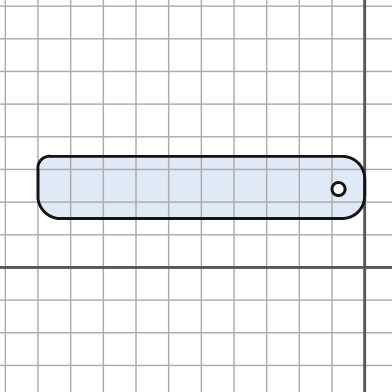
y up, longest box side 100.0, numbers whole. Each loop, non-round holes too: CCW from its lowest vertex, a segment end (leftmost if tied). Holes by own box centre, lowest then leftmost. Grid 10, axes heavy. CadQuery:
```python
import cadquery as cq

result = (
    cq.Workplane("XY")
    .moveTo(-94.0, 15.0)
    .lineTo(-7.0, 15.0)
    .threePointArc((-2.0, 17.0), (0.0, 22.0))
    .lineTo(0.0, 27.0)
    .threePointArc((-2.0, 32.0), (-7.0, 34.0))
    .lineTo(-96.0, 34.0)
    .threePointArc((-99.0, 33.0), (-100.0, 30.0))
    .lineTo(-100.0, 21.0)
    .threePointArc((-98.0, 17.0), (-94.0, 15.0))
    .close()
    .moveTo(-8.0, 24.0)
    .circle(2.0)
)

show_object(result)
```